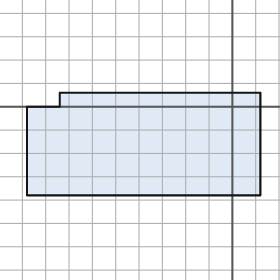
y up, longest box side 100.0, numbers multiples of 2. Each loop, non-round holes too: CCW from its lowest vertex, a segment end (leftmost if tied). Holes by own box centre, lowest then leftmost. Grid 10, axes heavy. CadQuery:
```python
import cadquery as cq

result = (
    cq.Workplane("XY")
    .moveTo(-88.0, -38.0)
    .lineTo(12.0, -38.0)
    .lineTo(12.0, 6.0)
    .lineTo(-74.0, 6.0)
    .lineTo(-74.0, 0.0)
    .lineTo(-88.0, 0.0)
    .close()
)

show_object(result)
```